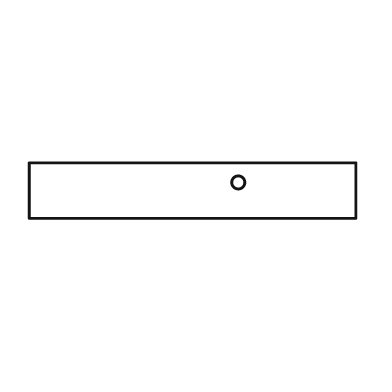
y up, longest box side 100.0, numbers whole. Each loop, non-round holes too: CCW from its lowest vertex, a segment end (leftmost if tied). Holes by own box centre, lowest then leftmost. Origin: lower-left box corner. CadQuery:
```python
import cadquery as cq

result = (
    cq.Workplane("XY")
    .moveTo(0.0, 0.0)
    .lineTo(100.0, 0.0)
    .lineTo(100.0, 17.0)
    .lineTo(0.0, 17.0)
    .close()
    .moveTo(64.0, 11.0)
    .circle(2.0)
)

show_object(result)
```